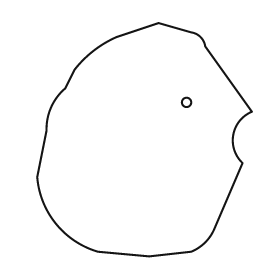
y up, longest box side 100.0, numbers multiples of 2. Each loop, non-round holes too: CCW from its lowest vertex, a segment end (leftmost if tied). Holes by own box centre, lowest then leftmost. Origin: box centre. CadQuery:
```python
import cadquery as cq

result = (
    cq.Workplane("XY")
    .moveTo(2.0, -50.0)
    .lineTo(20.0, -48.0)
    .threePointArc((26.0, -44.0), (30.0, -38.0))
    .lineTo(42.0, -10.0)
    .threePointArc((38.0, 2.0), (46.0, 12.0))
    .lineTo(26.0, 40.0)
    .threePointArc((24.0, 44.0), (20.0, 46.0))
    .lineTo(6.0, 50.0)
    .lineTo(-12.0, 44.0)
    .threePointArc((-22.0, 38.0), (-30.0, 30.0))
    .lineTo(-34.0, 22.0)
    .threePointArc((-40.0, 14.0), (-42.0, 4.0))
    .lineTo(-46.0, -16.0)
    .threePointArc((-38.0, -36.0), (-20.0, -48.0))
    .close()
    .moveTo(18.0, 16.0)
    .circle(2.0)
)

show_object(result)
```